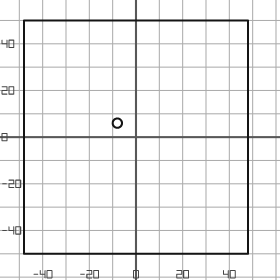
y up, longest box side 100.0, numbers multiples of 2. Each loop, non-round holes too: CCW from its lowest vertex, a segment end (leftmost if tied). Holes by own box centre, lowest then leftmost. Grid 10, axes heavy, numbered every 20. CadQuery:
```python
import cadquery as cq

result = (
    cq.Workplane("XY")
    .moveTo(-48.0, -50.0)
    .lineTo(48.0, -50.0)
    .lineTo(48.0, 50.0)
    .lineTo(-48.0, 50.0)
    .close()
    .moveTo(-8.0, 6.0)
    .circle(2.0)
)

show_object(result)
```